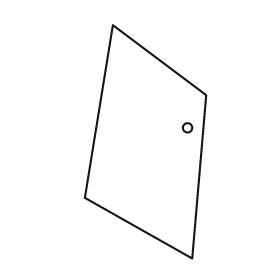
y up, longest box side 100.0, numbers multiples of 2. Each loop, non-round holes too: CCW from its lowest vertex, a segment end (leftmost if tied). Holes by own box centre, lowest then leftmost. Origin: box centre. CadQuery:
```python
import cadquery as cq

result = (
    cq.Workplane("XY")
    .moveTo(20.0, -50.0)
    .lineTo(26.0, 20.0)
    .lineTo(-14.0, 50.0)
    .lineTo(-26.0, -24.0)
    .close()
    .moveTo(18.0, 6.0)
    .circle(2.0)
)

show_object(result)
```